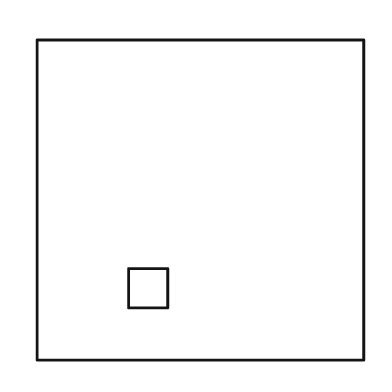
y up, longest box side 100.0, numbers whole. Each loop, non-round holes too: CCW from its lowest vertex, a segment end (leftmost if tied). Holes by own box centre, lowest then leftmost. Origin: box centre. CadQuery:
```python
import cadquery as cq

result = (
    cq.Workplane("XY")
    .moveTo(-50.0, -49.0)
    .lineTo(50.0, -49.0)
    .lineTo(50.0, 49.0)
    .lineTo(-50.0, 49.0)
    .close()
    .moveTo(-22.0, -33.0)
    .lineTo(-10.0, -33.0)
    .lineTo(-10.0, -21.0)
    .lineTo(-22.0, -21.0)
    .close()
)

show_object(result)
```